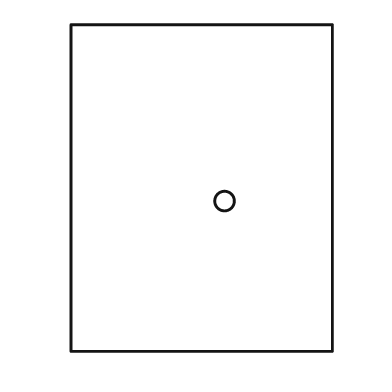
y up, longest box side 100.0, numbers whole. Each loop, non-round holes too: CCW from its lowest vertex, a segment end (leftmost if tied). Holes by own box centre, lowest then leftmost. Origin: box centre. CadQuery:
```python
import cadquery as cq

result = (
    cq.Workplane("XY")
    .moveTo(-40.0, -50.0)
    .lineTo(40.0, -50.0)
    .lineTo(40.0, 50.0)
    .lineTo(-40.0, 50.0)
    .close()
    .moveTo(7.0, -4.0)
    .circle(3.0)
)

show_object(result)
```